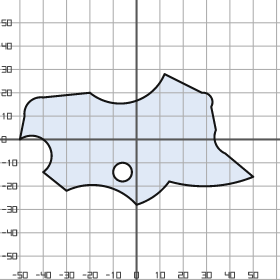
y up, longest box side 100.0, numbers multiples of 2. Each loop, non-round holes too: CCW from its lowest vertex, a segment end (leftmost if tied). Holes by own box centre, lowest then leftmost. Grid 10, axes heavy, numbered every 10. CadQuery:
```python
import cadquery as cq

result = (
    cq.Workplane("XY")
    .moveTo(0.0, -28.0)
    .threePointArc((8.0, -24.0), (14.0, -18.0))
    .threePointArc((32.0, -20.0), (50.0, -16.0))
    .lineTo(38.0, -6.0)
    .threePointArc((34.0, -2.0), (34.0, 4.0))
    .lineTo(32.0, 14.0)
    .threePointArc((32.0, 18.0), (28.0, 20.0))
    .lineTo(12.0, 28.0)
    .threePointArc((-2.0, 16.0), (-20.0, 20.0))
    .lineTo(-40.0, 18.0)
    .threePointArc((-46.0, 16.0), (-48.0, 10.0))
    .lineTo(-50.0, 0.0)
    .threePointArc((-38.0, -2.0), (-40.0, -14.0))
    .lineTo(-30.0, -22.0)
    .threePointArc((-14.0, -20.0), (0.0, -28.0))
    .close()
    .moveTo(-6.0, -14.0)
    .circle(4.0)
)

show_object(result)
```